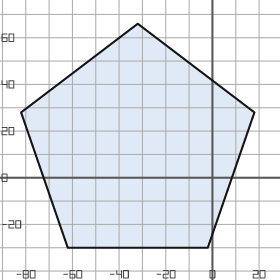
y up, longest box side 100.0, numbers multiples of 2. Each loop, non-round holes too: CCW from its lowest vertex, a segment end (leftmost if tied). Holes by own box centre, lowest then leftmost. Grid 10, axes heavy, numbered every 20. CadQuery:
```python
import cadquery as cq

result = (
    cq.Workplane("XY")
    .moveTo(-62.0, -30.0)
    .lineTo(-2.0, -30.0)
    .lineTo(18.0, 28.0)
    .lineTo(-32.0, 66.0)
    .lineTo(-82.0, 28.0)
    .close()
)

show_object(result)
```